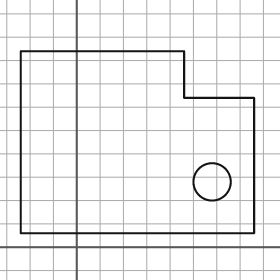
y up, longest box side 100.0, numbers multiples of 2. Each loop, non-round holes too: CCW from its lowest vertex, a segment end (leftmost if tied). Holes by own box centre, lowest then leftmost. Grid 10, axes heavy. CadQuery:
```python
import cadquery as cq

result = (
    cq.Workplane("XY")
    .moveTo(-24.0, 6.0)
    .lineTo(76.0, 6.0)
    .lineTo(76.0, 64.0)
    .lineTo(46.0, 64.0)
    .lineTo(46.0, 84.0)
    .lineTo(-24.0, 84.0)
    .close()
    .moveTo(58.0, 28.0)
    .circle(8.0)
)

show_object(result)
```